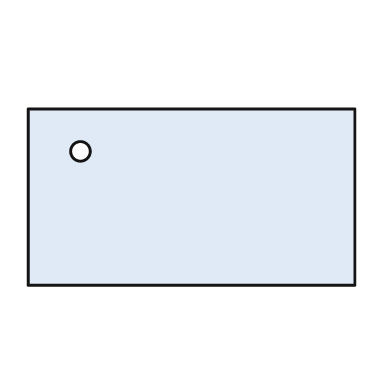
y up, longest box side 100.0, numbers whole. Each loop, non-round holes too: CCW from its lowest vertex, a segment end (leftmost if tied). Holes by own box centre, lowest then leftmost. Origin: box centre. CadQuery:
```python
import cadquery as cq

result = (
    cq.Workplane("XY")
    .moveTo(-50.0, -27.0)
    .lineTo(50.0, -27.0)
    .lineTo(50.0, 27.0)
    .lineTo(-50.0, 27.0)
    .close()
    .moveTo(-34.0, 14.0)
    .circle(3.0)
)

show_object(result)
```